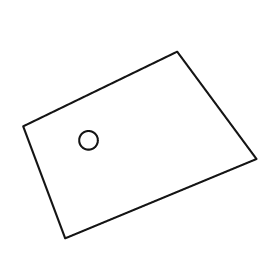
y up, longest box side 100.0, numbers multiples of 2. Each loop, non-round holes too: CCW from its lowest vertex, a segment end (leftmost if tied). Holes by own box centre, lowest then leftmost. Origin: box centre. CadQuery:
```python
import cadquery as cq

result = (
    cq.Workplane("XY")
    .moveTo(-32.0, -40.0)
    .lineTo(50.0, -6.0)
    .lineTo(16.0, 40.0)
    .lineTo(-50.0, 8.0)
    .close()
    .moveTo(-22.0, 2.0)
    .circle(4.0)
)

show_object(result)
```